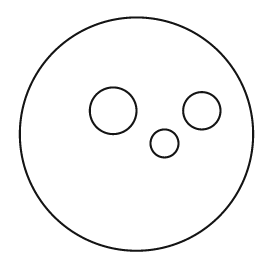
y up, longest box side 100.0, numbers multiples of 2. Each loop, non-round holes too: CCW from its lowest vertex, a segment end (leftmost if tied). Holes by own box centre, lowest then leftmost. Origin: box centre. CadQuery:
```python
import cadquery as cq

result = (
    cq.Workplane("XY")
    .moveTo(0.0, 0.0)
    .circle(50.0)
    .moveTo(12.0, -4.0)
    .circle(6.0)
    .moveTo(-10.0, 10.0)
    .circle(10.0)
    .moveTo(28.0, 10.0)
    .circle(8.0)
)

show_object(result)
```